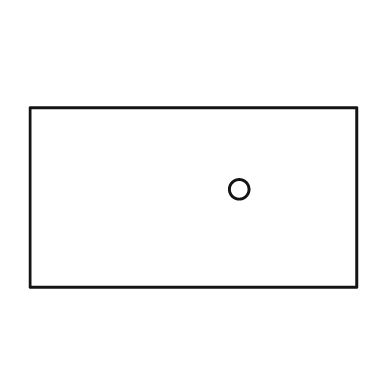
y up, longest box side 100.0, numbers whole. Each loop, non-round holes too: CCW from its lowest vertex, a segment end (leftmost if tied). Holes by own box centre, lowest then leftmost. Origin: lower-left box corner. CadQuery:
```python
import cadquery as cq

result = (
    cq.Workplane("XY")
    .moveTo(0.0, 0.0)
    .lineTo(100.0, 0.0)
    .lineTo(100.0, 55.0)
    .lineTo(0.0, 55.0)
    .close()
    .moveTo(64.0, 30.0)
    .circle(3.0)
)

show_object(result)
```